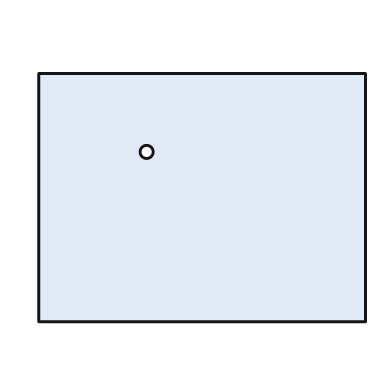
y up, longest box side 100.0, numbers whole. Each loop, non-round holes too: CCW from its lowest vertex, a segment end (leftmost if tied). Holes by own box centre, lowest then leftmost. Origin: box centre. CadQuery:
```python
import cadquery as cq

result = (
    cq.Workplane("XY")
    .moveTo(-50.0, -38.0)
    .lineTo(50.0, -38.0)
    .lineTo(50.0, 38.0)
    .lineTo(-50.0, 38.0)
    .close()
    .moveTo(-17.0, 14.0)
    .circle(2.0)
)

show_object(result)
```